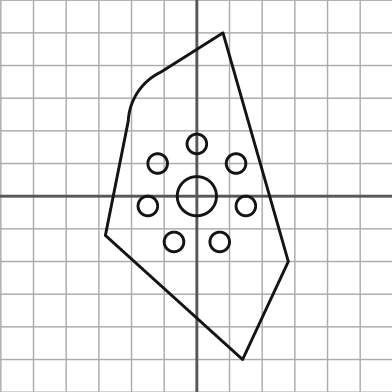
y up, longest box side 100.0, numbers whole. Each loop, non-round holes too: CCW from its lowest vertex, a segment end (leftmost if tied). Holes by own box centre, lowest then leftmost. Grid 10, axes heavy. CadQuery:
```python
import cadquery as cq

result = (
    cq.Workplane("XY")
    .moveTo(14.0, -50.0)
    .lineTo(28.0, -20.0)
    .lineTo(8.0, 50.0)
    .lineTo(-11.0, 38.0)
    .threePointArc((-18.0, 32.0), (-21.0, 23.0))
    .lineTo(-28.0, -12.0)
    .close()
    .moveTo(-7.0, -14.0)
    .circle(3.0)
    .moveTo(7.0, -14.0)
    .circle(3.0)
    .moveTo(-15.0, -3.0)
    .circle(3.0)
    .moveTo(15.0, -3.0)
    .circle(3.0)
    .moveTo(0.0, 0.0)
    .circle(6.0)
    .moveTo(-12.0, 10.0)
    .circle(3.0)
    .moveTo(12.0, 10.0)
    .circle(3.0)
    .moveTo(0.0, 16.0)
    .circle(3.0)
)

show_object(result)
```